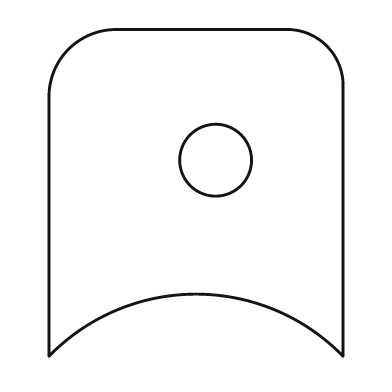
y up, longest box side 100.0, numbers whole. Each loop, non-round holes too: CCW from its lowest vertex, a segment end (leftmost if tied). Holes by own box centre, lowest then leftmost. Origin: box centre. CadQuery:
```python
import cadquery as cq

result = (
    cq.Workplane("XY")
    .moveTo(-45.0, -50.0)
    .threePointArc((0.0, -31.0), (45.0, -50.0))
    .lineTo(45.0, 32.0)
    .threePointArc((40.0, 45.0), (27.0, 50.0))
    .lineTo(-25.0, 50.0)
    .threePointArc((-39.0, 44.0), (-45.0, 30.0))
    .close()
    .moveTo(6.0, 10.0)
    .circle(11.0)
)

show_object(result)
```